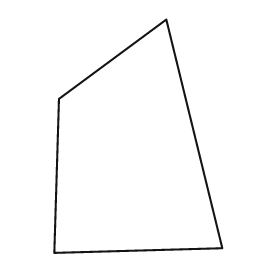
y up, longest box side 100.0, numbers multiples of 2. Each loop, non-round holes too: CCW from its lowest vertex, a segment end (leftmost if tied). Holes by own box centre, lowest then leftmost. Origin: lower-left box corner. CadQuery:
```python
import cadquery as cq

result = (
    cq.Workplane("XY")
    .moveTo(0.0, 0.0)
    .lineTo(72.0, 2.0)
    .lineTo(48.0, 100.0)
    .lineTo(2.0, 66.0)
    .close()
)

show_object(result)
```